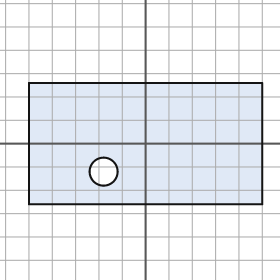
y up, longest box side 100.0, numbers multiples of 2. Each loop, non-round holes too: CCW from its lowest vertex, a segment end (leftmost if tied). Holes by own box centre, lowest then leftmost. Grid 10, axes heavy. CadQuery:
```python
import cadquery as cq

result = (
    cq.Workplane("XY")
    .moveTo(-50.0, -26.0)
    .lineTo(50.0, -26.0)
    .lineTo(50.0, 26.0)
    .lineTo(-50.0, 26.0)
    .close()
    .moveTo(-18.0, -12.0)
    .circle(6.0)
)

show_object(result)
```